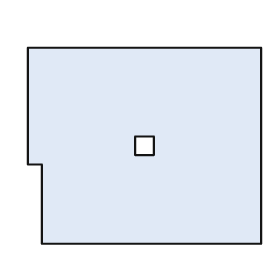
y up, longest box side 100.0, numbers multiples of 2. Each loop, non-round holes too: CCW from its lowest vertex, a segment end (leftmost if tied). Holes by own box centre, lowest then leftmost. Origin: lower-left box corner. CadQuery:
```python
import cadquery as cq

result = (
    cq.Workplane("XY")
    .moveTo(6.0, 0.0)
    .lineTo(100.0, 0.0)
    .lineTo(100.0, 84.0)
    .lineTo(0.0, 84.0)
    .lineTo(0.0, 34.0)
    .lineTo(6.0, 34.0)
    .close()
    .moveTo(46.0, 38.0)
    .lineTo(54.0, 38.0)
    .lineTo(54.0, 46.0)
    .lineTo(46.0, 46.0)
    .close()
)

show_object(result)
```